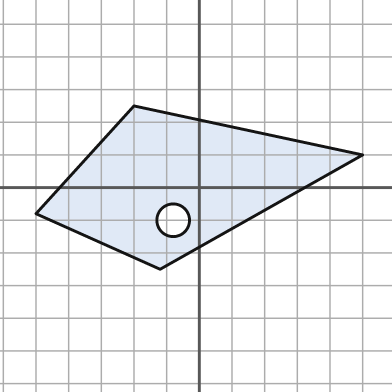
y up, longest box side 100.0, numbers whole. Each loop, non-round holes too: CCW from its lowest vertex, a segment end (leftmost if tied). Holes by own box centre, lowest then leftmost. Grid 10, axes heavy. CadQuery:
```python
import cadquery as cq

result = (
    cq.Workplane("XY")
    .moveTo(-12.0, -25.0)
    .lineTo(50.0, 10.0)
    .lineTo(-20.0, 25.0)
    .lineTo(-50.0, -8.0)
    .close()
    .moveTo(-8.0, -10.0)
    .circle(5.0)
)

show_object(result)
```